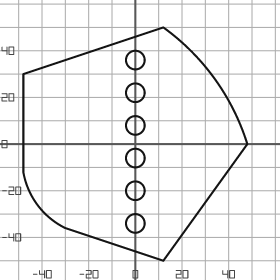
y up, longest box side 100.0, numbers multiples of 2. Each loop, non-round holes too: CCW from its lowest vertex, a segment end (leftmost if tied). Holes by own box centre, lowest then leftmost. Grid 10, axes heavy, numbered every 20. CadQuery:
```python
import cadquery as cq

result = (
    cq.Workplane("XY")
    .moveTo(12.0, -50.0)
    .lineTo(48.0, 0.0)
    .threePointArc((34.0, 28.0), (12.0, 50.0))
    .lineTo(-48.0, 30.0)
    .lineTo(-48.0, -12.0)
    .threePointArc((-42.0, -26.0), (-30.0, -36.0))
    .close()
    .moveTo(0.0, -34.0)
    .circle(4.0)
    .moveTo(0.0, -20.0)
    .circle(4.0)
    .moveTo(0.0, -6.0)
    .circle(4.0)
    .moveTo(0.0, 8.0)
    .circle(4.0)
    .moveTo(0.0, 22.0)
    .circle(4.0)
    .moveTo(0.0, 36.0)
    .circle(4.0)
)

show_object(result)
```